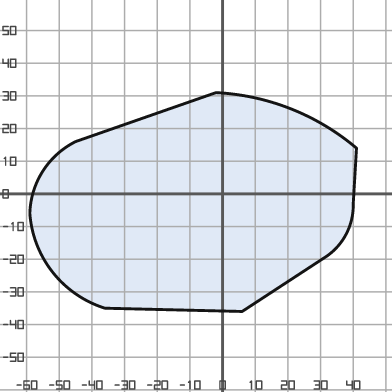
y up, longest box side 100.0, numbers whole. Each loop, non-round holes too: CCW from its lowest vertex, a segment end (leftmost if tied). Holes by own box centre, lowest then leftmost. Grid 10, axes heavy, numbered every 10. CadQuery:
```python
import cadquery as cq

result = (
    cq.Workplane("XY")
    .moveTo(6.0, -36.0)
    .lineTo(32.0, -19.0)
    .threePointArc((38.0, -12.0), (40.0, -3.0))
    .lineTo(41.0, 14.0)
    .threePointArc((21.0, 26.0), (-2.0, 31.0))
    .lineTo(-45.0, 16.0)
    .threePointArc((-55.0, 7.0), (-59.0, -6.0))
    .threePointArc((-52.0, -24.0), (-36.0, -35.0))
    .close()
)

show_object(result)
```